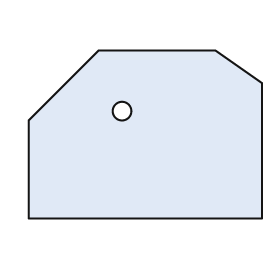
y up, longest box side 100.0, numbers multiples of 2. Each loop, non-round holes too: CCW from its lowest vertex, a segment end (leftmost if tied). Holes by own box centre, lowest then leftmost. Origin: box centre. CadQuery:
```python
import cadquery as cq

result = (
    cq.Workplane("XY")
    .moveTo(-50.0, -36.0)
    .lineTo(50.0, -36.0)
    .lineTo(50.0, 22.0)
    .lineTo(30.0, 36.0)
    .lineTo(-20.0, 36.0)
    .lineTo(-50.0, 6.0)
    .close()
    .moveTo(-10.0, 10.0)
    .circle(4.0)
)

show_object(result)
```